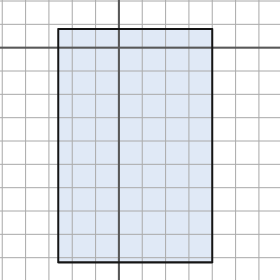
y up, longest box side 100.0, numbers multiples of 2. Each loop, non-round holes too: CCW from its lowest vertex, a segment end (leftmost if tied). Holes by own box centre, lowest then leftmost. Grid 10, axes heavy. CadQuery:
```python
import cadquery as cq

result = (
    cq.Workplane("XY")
    .moveTo(-26.0, -92.0)
    .lineTo(40.0, -92.0)
    .lineTo(40.0, 8.0)
    .lineTo(-26.0, 8.0)
    .close()
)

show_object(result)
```